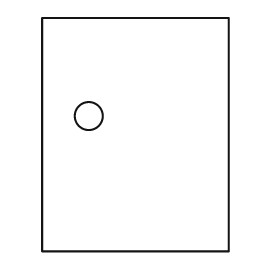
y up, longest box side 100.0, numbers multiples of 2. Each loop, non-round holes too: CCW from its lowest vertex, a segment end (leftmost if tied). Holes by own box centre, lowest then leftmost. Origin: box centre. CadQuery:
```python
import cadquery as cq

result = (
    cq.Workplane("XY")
    .moveTo(-40.0, -50.0)
    .lineTo(40.0, -50.0)
    .lineTo(40.0, 50.0)
    .lineTo(-40.0, 50.0)
    .close()
    .moveTo(-20.0, 8.0)
    .circle(6.0)
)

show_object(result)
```